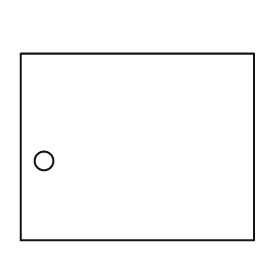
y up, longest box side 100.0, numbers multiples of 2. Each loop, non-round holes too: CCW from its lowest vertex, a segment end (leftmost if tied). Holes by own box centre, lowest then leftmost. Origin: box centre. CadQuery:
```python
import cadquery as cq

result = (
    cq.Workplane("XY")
    .moveTo(-50.0, -40.0)
    .lineTo(50.0, -40.0)
    .lineTo(50.0, 40.0)
    .lineTo(-50.0, 40.0)
    .close()
    .moveTo(-40.0, -6.0)
    .circle(4.0)
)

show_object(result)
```